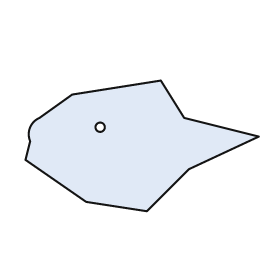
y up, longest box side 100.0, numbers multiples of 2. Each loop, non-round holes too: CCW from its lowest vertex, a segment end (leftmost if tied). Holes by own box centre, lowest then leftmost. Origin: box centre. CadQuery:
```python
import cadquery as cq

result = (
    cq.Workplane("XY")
    .moveTo(2.0, -28.0)
    .lineTo(20.0, -10.0)
    .lineTo(50.0, 4.0)
    .lineTo(18.0, 12.0)
    .lineTo(8.0, 28.0)
    .lineTo(-30.0, 22.0)
    .lineTo(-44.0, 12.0)
    .threePointArc((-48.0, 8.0), (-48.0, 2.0))
    .lineTo(-50.0, -6.0)
    .lineTo(-24.0, -24.0)
    .close()
    .moveTo(-18.0, 8.0)
    .circle(2.0)
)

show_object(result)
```